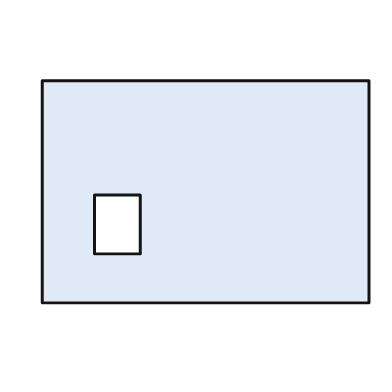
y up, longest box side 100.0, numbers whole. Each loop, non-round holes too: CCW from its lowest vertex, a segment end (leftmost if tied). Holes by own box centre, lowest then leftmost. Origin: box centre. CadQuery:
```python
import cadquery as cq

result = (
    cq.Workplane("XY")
    .moveTo(-50.0, -34.0)
    .lineTo(50.0, -34.0)
    .lineTo(50.0, 34.0)
    .lineTo(-50.0, 34.0)
    .close()
    .moveTo(-34.0, -19.0)
    .lineTo(-20.0, -19.0)
    .lineTo(-20.0, -1.0)
    .lineTo(-34.0, -1.0)
    .close()
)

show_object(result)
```